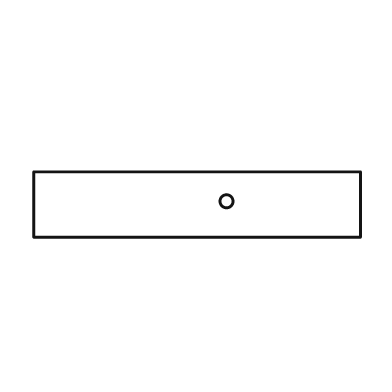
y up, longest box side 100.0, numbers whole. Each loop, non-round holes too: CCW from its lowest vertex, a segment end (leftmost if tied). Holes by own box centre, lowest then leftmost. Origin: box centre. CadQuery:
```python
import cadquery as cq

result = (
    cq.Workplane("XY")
    .moveTo(-50.0, -10.0)
    .lineTo(50.0, -10.0)
    .lineTo(50.0, 10.0)
    .lineTo(-50.0, 10.0)
    .close()
    .moveTo(9.0, 1.0)
    .circle(2.0)
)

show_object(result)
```